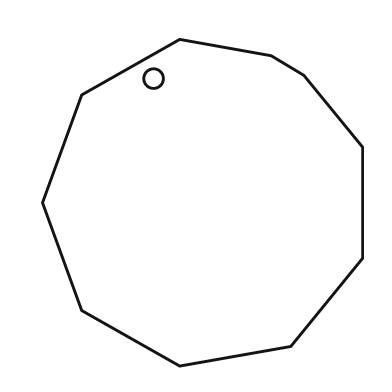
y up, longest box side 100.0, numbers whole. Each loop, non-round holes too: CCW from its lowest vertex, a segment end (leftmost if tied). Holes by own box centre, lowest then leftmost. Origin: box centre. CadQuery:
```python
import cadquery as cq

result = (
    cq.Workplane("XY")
    .moveTo(-7.0, -50.0)
    .lineTo(27.0, -44.0)
    .lineTo(49.0, -17.0)
    .lineTo(49.0, 17.0)
    .lineTo(31.0, 39.0)
    .lineTo(21.0, 45.0)
    .lineTo(-7.0, 50.0)
    .lineTo(-37.0, 33.0)
    .lineTo(-49.0, 0.0)
    .lineTo(-37.0, -33.0)
    .close()
    .moveTo(-15.0, 38.0)
    .circle(3.0)
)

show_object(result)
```